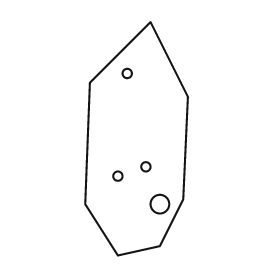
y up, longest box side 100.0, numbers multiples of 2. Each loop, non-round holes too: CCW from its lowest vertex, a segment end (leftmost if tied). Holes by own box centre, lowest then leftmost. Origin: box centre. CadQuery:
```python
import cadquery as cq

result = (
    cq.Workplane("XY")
    .moveTo(-8.0, -50.0)
    .lineTo(10.0, -46.0)
    .lineTo(20.0, -26.0)
    .lineTo(22.0, 18.0)
    .lineTo(6.0, 50.0)
    .lineTo(-20.0, 24.0)
    .lineTo(-22.0, -28.0)
    .close()
    .moveTo(10.0, -28.0)
    .circle(4.0)
    .moveTo(-8.0, -16.0)
    .circle(2.0)
    .moveTo(4.0, -12.0)
    .circle(2.0)
    .moveTo(-4.0, 28.0)
    .circle(2.0)
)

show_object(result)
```